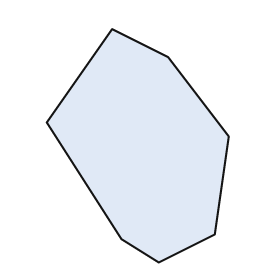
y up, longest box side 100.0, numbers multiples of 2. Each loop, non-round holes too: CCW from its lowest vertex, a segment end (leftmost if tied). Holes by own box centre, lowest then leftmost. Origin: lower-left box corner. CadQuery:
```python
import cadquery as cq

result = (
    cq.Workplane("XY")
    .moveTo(48.0, 0.0)
    .lineTo(72.0, 12.0)
    .lineTo(78.0, 54.0)
    .lineTo(52.0, 88.0)
    .lineTo(28.0, 100.0)
    .lineTo(0.0, 60.0)
    .lineTo(32.0, 10.0)
    .close()
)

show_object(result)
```